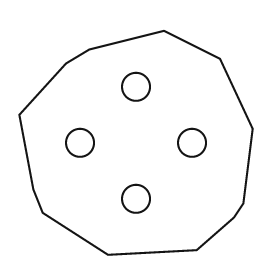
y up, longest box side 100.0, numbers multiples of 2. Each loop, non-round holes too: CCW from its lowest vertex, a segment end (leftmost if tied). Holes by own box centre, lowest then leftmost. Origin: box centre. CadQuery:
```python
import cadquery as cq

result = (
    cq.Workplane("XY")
    .moveTo(-12.0, -48.0)
    .lineTo(26.0, -46.0)
    .lineTo(42.0, -32.0)
    .lineTo(46.0, -26.0)
    .lineTo(50.0, 6.0)
    .lineTo(36.0, 36.0)
    .lineTo(12.0, 48.0)
    .lineTo(-20.0, 40.0)
    .lineTo(-30.0, 34.0)
    .lineTo(-50.0, 12.0)
    .lineTo(-44.0, -20.0)
    .lineTo(-40.0, -30.0)
    .close()
    .moveTo(0.0, -24.0)
    .circle(6.0)
    .moveTo(-24.0, 0.0)
    .circle(6.0)
    .moveTo(24.0, 0.0)
    .circle(6.0)
    .moveTo(0.0, 24.0)
    .circle(6.0)
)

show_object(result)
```